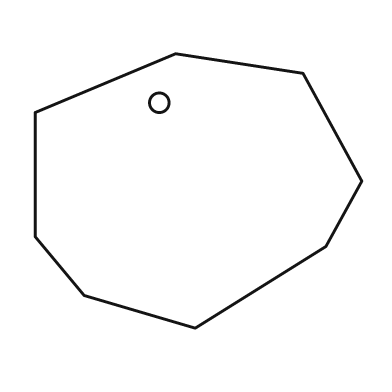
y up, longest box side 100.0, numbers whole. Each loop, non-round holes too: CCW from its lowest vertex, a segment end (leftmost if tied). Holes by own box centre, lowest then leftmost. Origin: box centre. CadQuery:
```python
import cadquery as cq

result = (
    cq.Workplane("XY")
    .moveTo(-1.0, -42.0)
    .lineTo(39.0, -17.0)
    .lineTo(50.0, 3.0)
    .lineTo(32.0, 36.0)
    .lineTo(-7.0, 42.0)
    .lineTo(-50.0, 24.0)
    .lineTo(-50.0, -14.0)
    .lineTo(-35.0, -32.0)
    .close()
    .moveTo(-12.0, 27.0)
    .circle(3.0)
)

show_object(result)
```